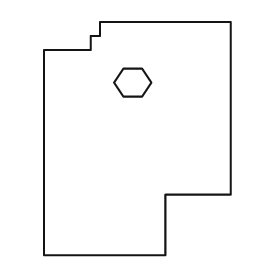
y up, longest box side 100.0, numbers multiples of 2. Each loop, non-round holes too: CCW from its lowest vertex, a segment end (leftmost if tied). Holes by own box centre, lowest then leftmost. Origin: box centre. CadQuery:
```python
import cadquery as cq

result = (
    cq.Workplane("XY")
    .moveTo(-40.0, -50.0)
    .lineTo(12.0, -50.0)
    .lineTo(12.0, -24.0)
    .lineTo(40.0, -24.0)
    .lineTo(40.0, 50.0)
    .lineTo(-16.0, 50.0)
    .lineTo(-16.0, 44.0)
    .lineTo(-20.0, 44.0)
    .lineTo(-20.0, 38.0)
    .lineTo(-40.0, 38.0)
    .close()
    .moveTo(-6.0, 18.0)
    .lineTo(2.0, 18.0)
    .lineTo(6.0, 24.0)
    .lineTo(2.0, 30.0)
    .lineTo(-6.0, 30.0)
    .lineTo(-10.0, 24.0)
    .close()
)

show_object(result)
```